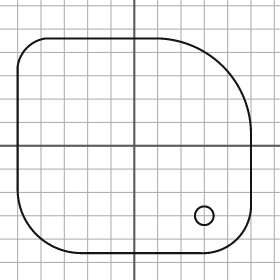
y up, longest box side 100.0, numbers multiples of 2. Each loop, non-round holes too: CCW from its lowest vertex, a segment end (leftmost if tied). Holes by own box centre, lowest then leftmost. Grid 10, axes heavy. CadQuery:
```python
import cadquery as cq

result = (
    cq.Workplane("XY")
    .moveTo(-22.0, -46.0)
    .lineTo(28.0, -46.0)
    .threePointArc((44.0, -40.0), (50.0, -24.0))
    .lineTo(50.0, 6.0)
    .threePointArc((38.0, 34.0), (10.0, 46.0))
    .lineTo(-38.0, 46.0)
    .threePointArc((-46.0, 42.0), (-50.0, 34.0))
    .lineTo(-50.0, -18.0)
    .threePointArc((-42.0, -38.0), (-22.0, -46.0))
    .close()
    .moveTo(30.0, -30.0)
    .circle(4.0)
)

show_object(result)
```